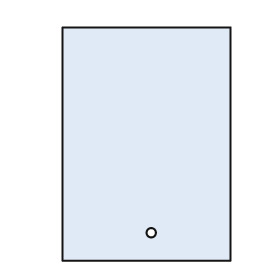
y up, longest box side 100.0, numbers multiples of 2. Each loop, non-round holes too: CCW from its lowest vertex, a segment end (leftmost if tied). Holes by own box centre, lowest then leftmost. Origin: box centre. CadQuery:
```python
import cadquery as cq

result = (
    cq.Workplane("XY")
    .moveTo(-36.0, -50.0)
    .lineTo(36.0, -50.0)
    .lineTo(36.0, 50.0)
    .lineTo(-36.0, 50.0)
    .close()
    .moveTo(2.0, -38.0)
    .circle(2.0)
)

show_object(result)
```